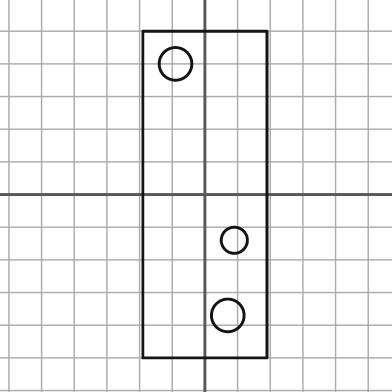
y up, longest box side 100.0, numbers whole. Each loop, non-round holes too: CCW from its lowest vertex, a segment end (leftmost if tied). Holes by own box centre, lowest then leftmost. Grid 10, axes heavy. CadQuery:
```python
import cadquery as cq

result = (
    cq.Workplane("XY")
    .moveTo(-19.0, -50.0)
    .lineTo(19.0, -50.0)
    .lineTo(19.0, 50.0)
    .lineTo(-19.0, 50.0)
    .close()
    .moveTo(7.0, -37.0)
    .circle(5.0)
    .moveTo(9.0, -14.0)
    .circle(4.0)
    .moveTo(-9.0, 40.0)
    .circle(5.0)
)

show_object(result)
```